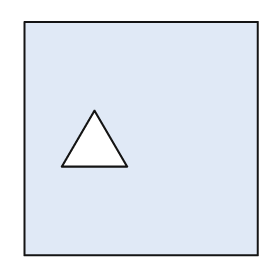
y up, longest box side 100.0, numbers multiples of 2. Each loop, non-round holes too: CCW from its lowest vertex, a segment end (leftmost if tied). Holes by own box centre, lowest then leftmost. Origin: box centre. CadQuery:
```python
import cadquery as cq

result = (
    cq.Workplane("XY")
    .moveTo(-50.0, -50.0)
    .lineTo(50.0, -50.0)
    .lineTo(50.0, 50.0)
    .lineTo(-50.0, 50.0)
    .close()
    .moveTo(-34.0, -12.0)
    .lineTo(-6.0, -12.0)
    .lineTo(-20.0, 12.0)
    .close()
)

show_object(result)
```